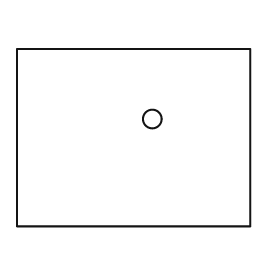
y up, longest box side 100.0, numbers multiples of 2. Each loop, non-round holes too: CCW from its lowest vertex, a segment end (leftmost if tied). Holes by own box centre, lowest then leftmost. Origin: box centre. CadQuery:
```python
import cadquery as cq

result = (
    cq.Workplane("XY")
    .moveTo(-50.0, -38.0)
    .lineTo(50.0, -38.0)
    .lineTo(50.0, 38.0)
    .lineTo(-50.0, 38.0)
    .close()
    .moveTo(8.0, 8.0)
    .circle(4.0)
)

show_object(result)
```